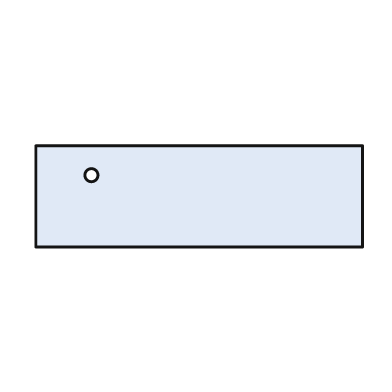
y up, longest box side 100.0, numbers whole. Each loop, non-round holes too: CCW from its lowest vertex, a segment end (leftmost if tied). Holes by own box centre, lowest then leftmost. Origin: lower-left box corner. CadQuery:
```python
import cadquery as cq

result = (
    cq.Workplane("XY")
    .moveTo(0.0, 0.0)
    .lineTo(100.0, 0.0)
    .lineTo(100.0, 31.0)
    .lineTo(0.0, 31.0)
    .close()
    .moveTo(17.0, 22.0)
    .circle(2.0)
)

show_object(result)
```